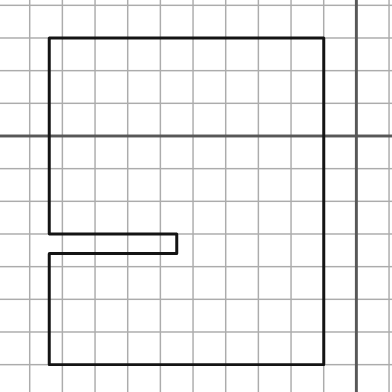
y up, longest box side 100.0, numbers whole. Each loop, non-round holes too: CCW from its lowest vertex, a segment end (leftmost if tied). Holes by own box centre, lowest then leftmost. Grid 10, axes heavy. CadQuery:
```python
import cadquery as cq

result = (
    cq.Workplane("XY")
    .moveTo(-94.0, -70.0)
    .lineTo(-10.0, -70.0)
    .lineTo(-10.0, 30.0)
    .lineTo(-94.0, 30.0)
    .lineTo(-94.0, -30.0)
    .lineTo(-55.0, -30.0)
    .lineTo(-55.0, -36.0)
    .lineTo(-94.0, -36.0)
    .close()
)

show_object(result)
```